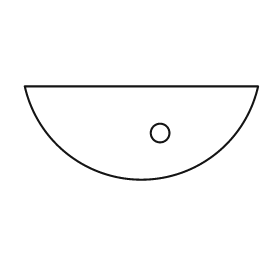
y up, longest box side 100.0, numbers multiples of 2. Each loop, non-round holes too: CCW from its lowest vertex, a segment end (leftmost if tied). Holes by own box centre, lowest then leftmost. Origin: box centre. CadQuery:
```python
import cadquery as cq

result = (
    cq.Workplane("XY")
    .moveTo(-50.0, 20.0)
    .threePointArc((0.0, -20.0), (50.0, 20.0))
    .close()
    .moveTo(8.0, 0.0)
    .circle(4.0)
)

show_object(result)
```